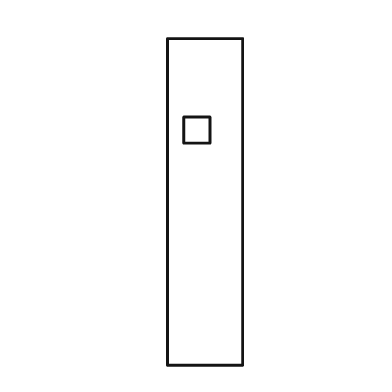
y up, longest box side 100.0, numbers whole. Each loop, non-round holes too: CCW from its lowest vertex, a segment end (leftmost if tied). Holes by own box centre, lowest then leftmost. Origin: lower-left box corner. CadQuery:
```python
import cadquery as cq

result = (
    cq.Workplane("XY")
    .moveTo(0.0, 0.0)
    .lineTo(23.0, 0.0)
    .lineTo(23.0, 100.0)
    .lineTo(0.0, 100.0)
    .close()
    .moveTo(5.0, 68.0)
    .lineTo(13.0, 68.0)
    .lineTo(13.0, 76.0)
    .lineTo(5.0, 76.0)
    .close()
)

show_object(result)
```